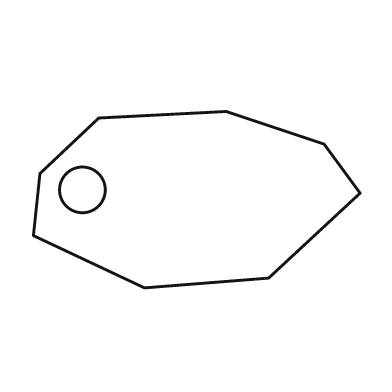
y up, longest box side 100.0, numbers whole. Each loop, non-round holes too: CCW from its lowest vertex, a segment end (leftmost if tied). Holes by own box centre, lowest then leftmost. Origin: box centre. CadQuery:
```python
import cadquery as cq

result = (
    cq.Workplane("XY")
    .moveTo(-16.0, -27.0)
    .lineTo(22.0, -24.0)
    .lineTo(50.0, 2.0)
    .lineTo(39.0, 17.0)
    .lineTo(9.0, 27.0)
    .lineTo(-30.0, 25.0)
    .lineTo(-48.0, 8.0)
    .lineTo(-50.0, -11.0)
    .close()
    .moveTo(-35.0, 3.0)
    .circle(7.0)
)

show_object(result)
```